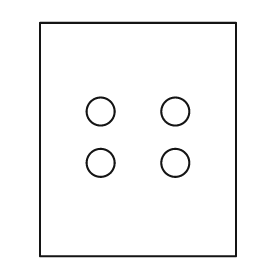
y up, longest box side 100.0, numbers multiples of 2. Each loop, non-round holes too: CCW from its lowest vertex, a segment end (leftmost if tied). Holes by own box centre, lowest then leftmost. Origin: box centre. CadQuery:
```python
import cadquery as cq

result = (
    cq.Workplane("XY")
    .moveTo(-42.0, -50.0)
    .lineTo(42.0, -50.0)
    .lineTo(42.0, 50.0)
    .lineTo(-42.0, 50.0)
    .close()
    .moveTo(-16.0, -10.0)
    .circle(6.0)
    .moveTo(16.0, -10.0)
    .circle(6.0)
    .moveTo(-16.0, 12.0)
    .circle(6.0)
    .moveTo(16.0, 12.0)
    .circle(6.0)
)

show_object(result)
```